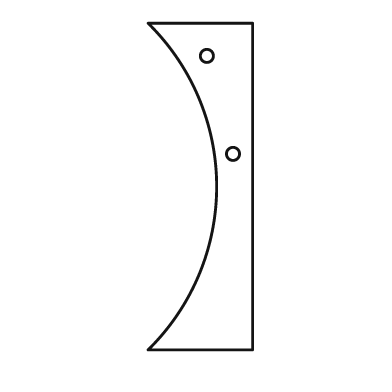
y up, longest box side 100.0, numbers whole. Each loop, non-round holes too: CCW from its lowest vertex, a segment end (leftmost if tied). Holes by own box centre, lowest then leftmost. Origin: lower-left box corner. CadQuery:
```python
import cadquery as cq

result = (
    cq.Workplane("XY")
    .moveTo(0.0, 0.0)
    .lineTo(32.0, 0.0)
    .lineTo(32.0, 100.0)
    .lineTo(0.0, 100.0)
    .threePointArc((21.0, 50.0), (0.0, 0.0))
    .close()
    .moveTo(26.0, 60.0)
    .circle(2.0)
    .moveTo(18.0, 90.0)
    .circle(2.0)
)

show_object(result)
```